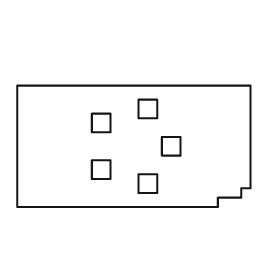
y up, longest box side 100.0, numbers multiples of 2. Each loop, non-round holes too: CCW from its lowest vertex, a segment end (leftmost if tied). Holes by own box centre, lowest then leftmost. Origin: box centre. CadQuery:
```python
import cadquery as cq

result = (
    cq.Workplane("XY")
    .moveTo(-50.0, -26.0)
    .lineTo(36.0, -26.0)
    .lineTo(36.0, -22.0)
    .lineTo(46.0, -22.0)
    .lineTo(46.0, -18.0)
    .lineTo(50.0, -18.0)
    .lineTo(50.0, 26.0)
    .lineTo(-50.0, 26.0)
    .close()
    .moveTo(2.0, -20.0)
    .lineTo(10.0, -20.0)
    .lineTo(10.0, -12.0)
    .lineTo(2.0, -12.0)
    .close()
    .moveTo(-18.0, -14.0)
    .lineTo(-10.0, -14.0)
    .lineTo(-10.0, -6.0)
    .lineTo(-18.0, -6.0)
    .close()
    .moveTo(12.0, -4.0)
    .lineTo(20.0, -4.0)
    .lineTo(20.0, 4.0)
    .lineTo(12.0, 4.0)
    .close()
    .moveTo(-18.0, 6.0)
    .lineTo(-10.0, 6.0)
    .lineTo(-10.0, 14.0)
    .lineTo(-18.0, 14.0)
    .close()
    .moveTo(2.0, 12.0)
    .lineTo(10.0, 12.0)
    .lineTo(10.0, 20.0)
    .lineTo(2.0, 20.0)
    .close()
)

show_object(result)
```